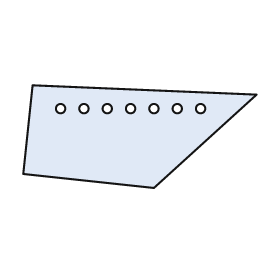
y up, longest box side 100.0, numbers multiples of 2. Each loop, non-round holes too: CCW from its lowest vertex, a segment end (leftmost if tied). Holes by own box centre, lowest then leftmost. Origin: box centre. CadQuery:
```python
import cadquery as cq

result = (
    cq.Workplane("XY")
    .moveTo(6.0, -22.0)
    .lineTo(50.0, 18.0)
    .lineTo(-46.0, 22.0)
    .lineTo(-50.0, -16.0)
    .close()
    .moveTo(-34.0, 12.0)
    .circle(2.0)
    .moveTo(-24.0, 12.0)
    .circle(2.0)
    .moveTo(-14.0, 12.0)
    .circle(2.0)
    .moveTo(-4.0, 12.0)
    .circle(2.0)
    .moveTo(6.0, 12.0)
    .circle(2.0)
    .moveTo(16.0, 12.0)
    .circle(2.0)
    .moveTo(26.0, 12.0)
    .circle(2.0)
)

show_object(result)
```